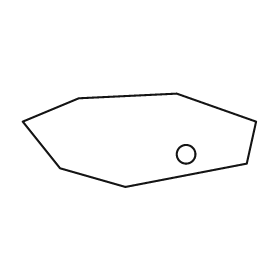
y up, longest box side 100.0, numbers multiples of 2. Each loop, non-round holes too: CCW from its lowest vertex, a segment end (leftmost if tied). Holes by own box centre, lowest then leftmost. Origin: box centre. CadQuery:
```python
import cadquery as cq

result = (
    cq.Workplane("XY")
    .moveTo(-6.0, -20.0)
    .lineTo(46.0, -10.0)
    .lineTo(50.0, 8.0)
    .lineTo(16.0, 20.0)
    .lineTo(-26.0, 18.0)
    .lineTo(-50.0, 8.0)
    .lineTo(-34.0, -12.0)
    .close()
    .moveTo(20.0, -6.0)
    .circle(4.0)
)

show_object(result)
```